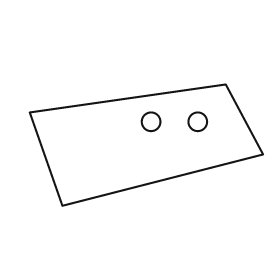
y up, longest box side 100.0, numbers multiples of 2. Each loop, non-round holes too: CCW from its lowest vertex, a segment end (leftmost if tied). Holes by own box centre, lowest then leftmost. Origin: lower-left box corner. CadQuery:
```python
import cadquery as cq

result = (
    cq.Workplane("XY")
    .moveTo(14.0, 0.0)
    .lineTo(100.0, 22.0)
    .lineTo(84.0, 52.0)
    .lineTo(0.0, 40.0)
    .close()
    .moveTo(52.0, 36.0)
    .circle(4.0)
    .moveTo(72.0, 36.0)
    .circle(4.0)
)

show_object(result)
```